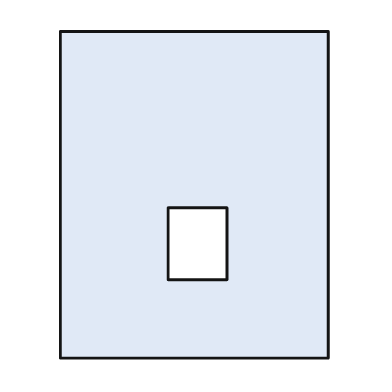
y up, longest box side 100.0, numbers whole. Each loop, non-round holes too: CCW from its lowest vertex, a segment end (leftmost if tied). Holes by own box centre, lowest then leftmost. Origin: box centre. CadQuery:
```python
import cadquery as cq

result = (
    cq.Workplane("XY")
    .moveTo(-41.0, -50.0)
    .lineTo(41.0, -50.0)
    .lineTo(41.0, 50.0)
    .lineTo(-41.0, 50.0)
    .close()
    .moveTo(-8.0, -26.0)
    .lineTo(10.0, -26.0)
    .lineTo(10.0, -4.0)
    .lineTo(-8.0, -4.0)
    .close()
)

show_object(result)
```